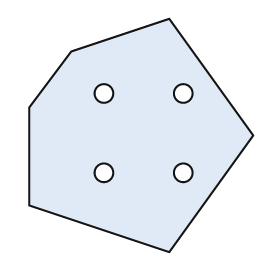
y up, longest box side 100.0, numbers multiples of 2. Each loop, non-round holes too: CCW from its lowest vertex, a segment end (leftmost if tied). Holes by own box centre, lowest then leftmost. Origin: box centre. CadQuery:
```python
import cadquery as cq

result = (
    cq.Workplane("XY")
    .moveTo(12.0, -50.0)
    .lineTo(48.0, 0.0)
    .lineTo(12.0, 50.0)
    .lineTo(-30.0, 36.0)
    .lineTo(-48.0, 12.0)
    .lineTo(-48.0, -30.0)
    .close()
    .moveTo(-16.0, -16.0)
    .circle(4.0)
    .moveTo(18.0, -16.0)
    .circle(4.0)
    .moveTo(-16.0, 18.0)
    .circle(4.0)
    .moveTo(18.0, 18.0)
    .circle(4.0)
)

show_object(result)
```